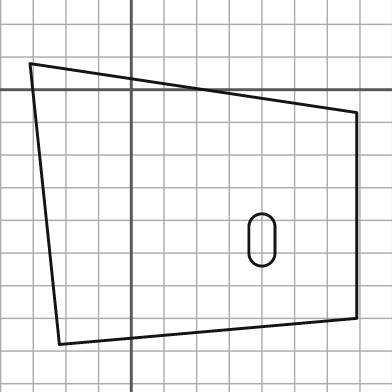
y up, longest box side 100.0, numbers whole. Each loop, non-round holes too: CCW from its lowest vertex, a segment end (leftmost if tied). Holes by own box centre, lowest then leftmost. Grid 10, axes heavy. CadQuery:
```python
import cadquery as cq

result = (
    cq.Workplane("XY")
    .moveTo(-22.0, -78.0)
    .lineTo(69.0, -70.0)
    .lineTo(69.0, -7.0)
    .lineTo(-31.0, 8.0)
    .close()
    .moveTo(36.0, -50.0)
    .threePointArc((40.0, -54.0), (44.0, -50.0))
    .lineTo(44.0, -42.0)
    .threePointArc((40.0, -38.0), (36.0, -42.0))
    .close()
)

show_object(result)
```